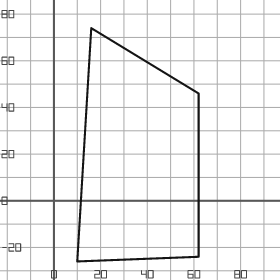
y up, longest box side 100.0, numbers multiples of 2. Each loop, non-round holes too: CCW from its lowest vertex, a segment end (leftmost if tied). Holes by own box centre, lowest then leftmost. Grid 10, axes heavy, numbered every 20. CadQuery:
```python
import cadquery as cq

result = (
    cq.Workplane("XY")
    .moveTo(10.0, -26.0)
    .lineTo(62.0, -24.0)
    .lineTo(62.0, 46.0)
    .lineTo(16.0, 74.0)
    .close()
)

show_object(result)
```